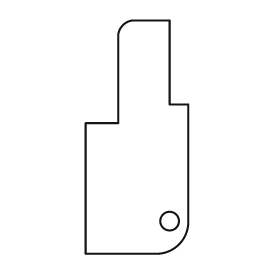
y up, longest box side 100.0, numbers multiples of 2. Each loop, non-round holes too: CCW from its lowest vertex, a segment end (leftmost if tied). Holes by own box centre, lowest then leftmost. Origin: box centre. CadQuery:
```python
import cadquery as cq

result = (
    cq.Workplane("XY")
    .moveTo(-22.0, -50.0)
    .lineTo(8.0, -50.0)
    .threePointArc((18.0, -46.0), (22.0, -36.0))
    .lineTo(22.0, 14.0)
    .lineTo(14.0, 14.0)
    .lineTo(14.0, 50.0)
    .lineTo(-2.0, 50.0)
    .threePointArc((-6.0, 48.0), (-8.0, 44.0))
    .lineTo(-8.0, 6.0)
    .lineTo(-22.0, 6.0)
    .close()
    .moveTo(14.0, -36.0)
    .circle(4.0)
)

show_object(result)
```